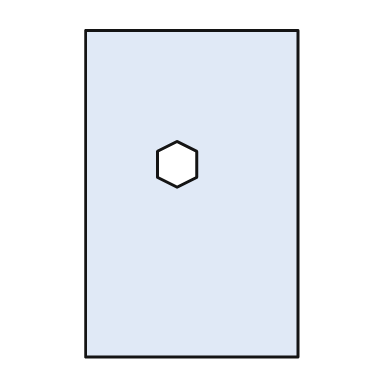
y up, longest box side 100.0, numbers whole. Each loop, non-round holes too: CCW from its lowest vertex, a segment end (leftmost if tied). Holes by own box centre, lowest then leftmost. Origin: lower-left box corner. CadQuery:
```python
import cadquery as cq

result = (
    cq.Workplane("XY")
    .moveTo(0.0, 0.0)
    .lineTo(65.0, 0.0)
    .lineTo(65.0, 100.0)
    .lineTo(0.0, 100.0)
    .close()
    .moveTo(28.0, 52.0)
    .lineTo(34.0, 55.0)
    .lineTo(34.0, 63.0)
    .lineTo(28.0, 66.0)
    .lineTo(22.0, 63.0)
    .lineTo(22.0, 55.0)
    .close()
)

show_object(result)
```